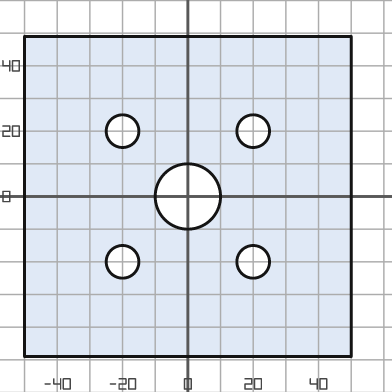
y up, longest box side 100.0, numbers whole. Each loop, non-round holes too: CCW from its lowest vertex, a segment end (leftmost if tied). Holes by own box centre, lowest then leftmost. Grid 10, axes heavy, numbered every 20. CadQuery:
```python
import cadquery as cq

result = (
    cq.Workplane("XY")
    .moveTo(-50.0, -49.0)
    .lineTo(50.0, -49.0)
    .lineTo(50.0, 49.0)
    .lineTo(-50.0, 49.0)
    .close()
    .moveTo(-20.0, -20.0)
    .circle(5.0)
    .moveTo(20.0, -20.0)
    .circle(5.0)
    .moveTo(0.0, 0.0)
    .circle(10.0)
    .moveTo(-20.0, 20.0)
    .circle(5.0)
    .moveTo(20.0, 20.0)
    .circle(5.0)
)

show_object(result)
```